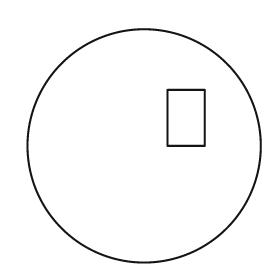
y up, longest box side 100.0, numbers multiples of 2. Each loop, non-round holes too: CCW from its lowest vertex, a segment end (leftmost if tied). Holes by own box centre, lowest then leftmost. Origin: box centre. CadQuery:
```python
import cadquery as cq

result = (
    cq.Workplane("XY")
    .moveTo(0.0, 0.0)
    .circle(50.0)
    .moveTo(10.0, 0.0)
    .lineTo(26.0, 0.0)
    .lineTo(26.0, 24.0)
    .lineTo(10.0, 24.0)
    .close()
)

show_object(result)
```